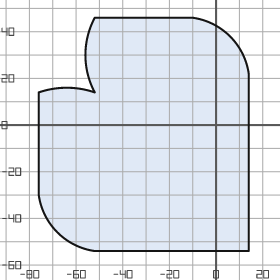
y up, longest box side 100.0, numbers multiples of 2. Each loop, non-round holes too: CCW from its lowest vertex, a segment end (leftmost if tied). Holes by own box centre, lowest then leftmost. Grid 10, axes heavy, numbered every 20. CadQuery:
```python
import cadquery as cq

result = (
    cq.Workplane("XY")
    .moveTo(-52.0, -54.0)
    .lineTo(14.0, -54.0)
    .lineTo(14.0, 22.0)
    .threePointArc((6.0, 38.0), (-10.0, 46.0))
    .lineTo(-52.0, 46.0)
    .threePointArc((-56.0, 30.0), (-52.0, 14.0))
    .threePointArc((-64.0, 16.0), (-76.0, 14.0))
    .lineTo(-76.0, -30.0)
    .threePointArc((-68.0, -46.0), (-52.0, -54.0))
    .close()
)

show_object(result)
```